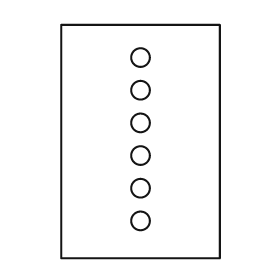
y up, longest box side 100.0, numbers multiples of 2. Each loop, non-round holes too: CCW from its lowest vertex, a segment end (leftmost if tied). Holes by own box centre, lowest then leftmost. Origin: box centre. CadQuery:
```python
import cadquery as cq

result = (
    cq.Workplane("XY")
    .moveTo(-34.0, -50.0)
    .lineTo(34.0, -50.0)
    .lineTo(34.0, 50.0)
    .lineTo(-34.0, 50.0)
    .close()
    .moveTo(0.0, -34.0)
    .circle(4.0)
    .moveTo(0.0, -20.0)
    .circle(4.0)
    .moveTo(0.0, -6.0)
    .circle(4.0)
    .moveTo(0.0, 8.0)
    .circle(4.0)
    .moveTo(0.0, 22.0)
    .circle(4.0)
    .moveTo(0.0, 36.0)
    .circle(4.0)
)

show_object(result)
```